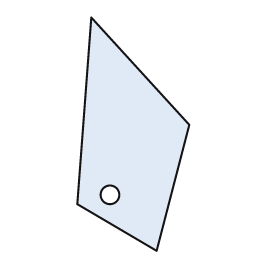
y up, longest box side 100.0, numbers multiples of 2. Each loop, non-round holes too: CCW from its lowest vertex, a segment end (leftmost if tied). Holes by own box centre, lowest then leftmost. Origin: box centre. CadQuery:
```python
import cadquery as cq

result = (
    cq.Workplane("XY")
    .moveTo(10.0, -50.0)
    .lineTo(24.0, 4.0)
    .lineTo(-18.0, 50.0)
    .lineTo(-24.0, -30.0)
    .close()
    .moveTo(-10.0, -26.0)
    .circle(4.0)
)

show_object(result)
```